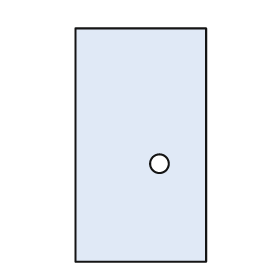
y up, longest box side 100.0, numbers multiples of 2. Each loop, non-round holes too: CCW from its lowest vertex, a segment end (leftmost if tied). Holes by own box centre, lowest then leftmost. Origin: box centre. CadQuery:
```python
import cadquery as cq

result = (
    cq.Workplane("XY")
    .moveTo(-28.0, -50.0)
    .lineTo(28.0, -50.0)
    .lineTo(28.0, 50.0)
    .lineTo(-28.0, 50.0)
    .close()
    .moveTo(8.0, -8.0)
    .circle(4.0)
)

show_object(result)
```